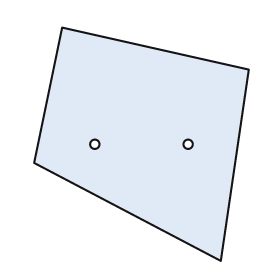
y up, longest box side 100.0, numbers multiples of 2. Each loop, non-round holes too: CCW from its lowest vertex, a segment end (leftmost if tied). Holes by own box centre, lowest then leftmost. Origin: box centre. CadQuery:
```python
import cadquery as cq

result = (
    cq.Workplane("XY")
    .moveTo(34.0, -50.0)
    .lineTo(46.0, 32.0)
    .lineTo(-34.0, 50.0)
    .lineTo(-46.0, -8.0)
    .close()
    .moveTo(-20.0, 0.0)
    .circle(2.0)
    .moveTo(20.0, 0.0)
    .circle(2.0)
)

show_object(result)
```